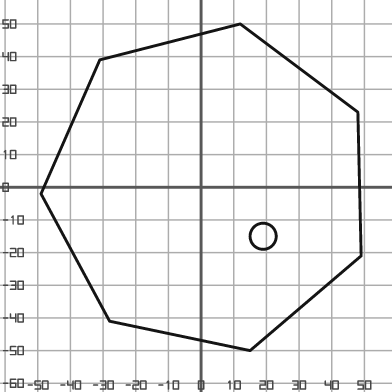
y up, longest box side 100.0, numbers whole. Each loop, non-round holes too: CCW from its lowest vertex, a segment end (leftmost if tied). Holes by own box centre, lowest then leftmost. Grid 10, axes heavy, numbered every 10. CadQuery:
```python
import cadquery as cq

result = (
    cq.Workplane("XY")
    .moveTo(15.0, -50.0)
    .lineTo(49.0, -21.0)
    .lineTo(48.0, 23.0)
    .lineTo(12.0, 50.0)
    .lineTo(-31.0, 39.0)
    .lineTo(-49.0, -2.0)
    .lineTo(-28.0, -41.0)
    .close()
    .moveTo(19.0, -15.0)
    .circle(4.0)
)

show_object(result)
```